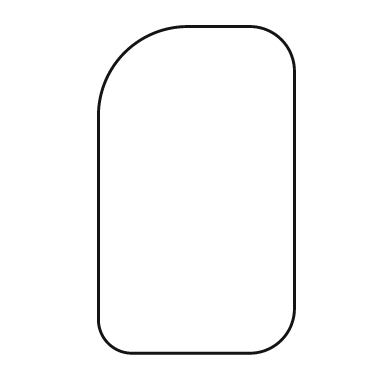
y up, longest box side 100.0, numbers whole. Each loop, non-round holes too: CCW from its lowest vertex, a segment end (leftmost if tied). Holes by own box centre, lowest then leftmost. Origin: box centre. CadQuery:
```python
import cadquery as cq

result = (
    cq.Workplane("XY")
    .moveTo(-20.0, -50.0)
    .lineTo(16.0, -50.0)
    .threePointArc((26.0, -46.0), (30.0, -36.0))
    .lineTo(30.0, 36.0)
    .threePointArc((26.0, 46.0), (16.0, 50.0))
    .lineTo(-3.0, 50.0)
    .threePointArc((-22.0, 42.0), (-30.0, 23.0))
    .lineTo(-30.0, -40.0)
    .threePointArc((-27.0, -47.0), (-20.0, -50.0))
    .close()
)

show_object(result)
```